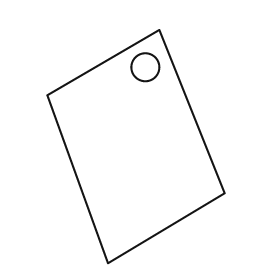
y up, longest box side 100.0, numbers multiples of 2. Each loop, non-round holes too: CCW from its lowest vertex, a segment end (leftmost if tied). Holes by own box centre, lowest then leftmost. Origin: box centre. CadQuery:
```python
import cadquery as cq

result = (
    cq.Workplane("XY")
    .moveTo(-12.0, -50.0)
    .lineTo(38.0, -20.0)
    .lineTo(10.0, 50.0)
    .lineTo(-38.0, 22.0)
    .close()
    .moveTo(4.0, 34.0)
    .circle(6.0)
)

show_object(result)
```